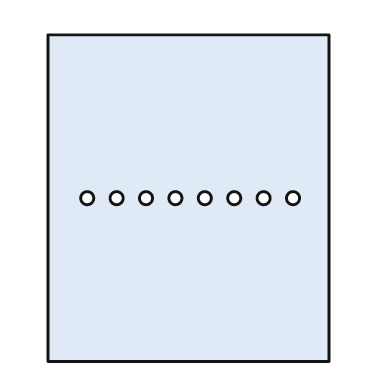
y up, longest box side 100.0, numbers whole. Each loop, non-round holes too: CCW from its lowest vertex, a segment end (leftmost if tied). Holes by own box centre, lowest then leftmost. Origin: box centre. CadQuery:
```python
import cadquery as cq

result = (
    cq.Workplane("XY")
    .moveTo(-43.0, -50.0)
    .lineTo(43.0, -50.0)
    .lineTo(43.0, 50.0)
    .lineTo(-43.0, 50.0)
    .close()
    .moveTo(-31.0, 0.0)
    .circle(2.0)
    .moveTo(-22.0, 0.0)
    .circle(2.0)
    .moveTo(-13.0, 0.0)
    .circle(2.0)
    .moveTo(-4.0, 0.0)
    .circle(2.0)
    .moveTo(5.0, 0.0)
    .circle(2.0)
    .moveTo(14.0, 0.0)
    .circle(2.0)
    .moveTo(23.0, 0.0)
    .circle(2.0)
    .moveTo(32.0, 0.0)
    .circle(2.0)
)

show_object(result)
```